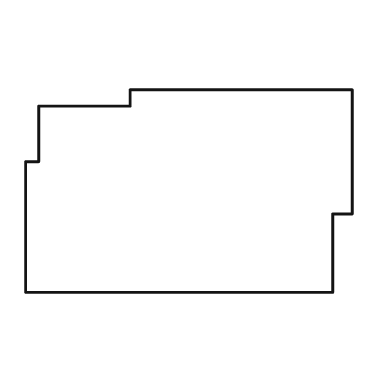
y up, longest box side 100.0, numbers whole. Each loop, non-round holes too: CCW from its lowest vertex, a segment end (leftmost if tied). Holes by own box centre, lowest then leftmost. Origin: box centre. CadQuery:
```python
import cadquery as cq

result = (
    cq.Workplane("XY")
    .moveTo(-50.0, -31.0)
    .lineTo(44.0, -31.0)
    .lineTo(44.0, -7.0)
    .lineTo(50.0, -7.0)
    .lineTo(50.0, 31.0)
    .lineTo(-18.0, 31.0)
    .lineTo(-18.0, 26.0)
    .lineTo(-46.0, 26.0)
    .lineTo(-46.0, 9.0)
    .lineTo(-50.0, 9.0)
    .close()
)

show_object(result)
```